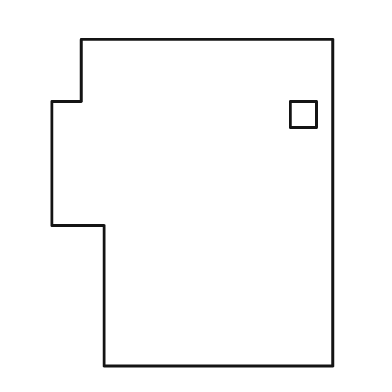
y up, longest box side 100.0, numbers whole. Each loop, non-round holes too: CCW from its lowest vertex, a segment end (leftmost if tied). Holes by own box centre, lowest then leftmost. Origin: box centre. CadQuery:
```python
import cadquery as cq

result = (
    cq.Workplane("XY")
    .moveTo(-27.0, -50.0)
    .lineTo(43.0, -50.0)
    .lineTo(43.0, 50.0)
    .lineTo(-34.0, 50.0)
    .lineTo(-34.0, 31.0)
    .lineTo(-43.0, 31.0)
    .lineTo(-43.0, -7.0)
    .lineTo(-27.0, -7.0)
    .close()
    .moveTo(30.0, 23.0)
    .lineTo(38.0, 23.0)
    .lineTo(38.0, 31.0)
    .lineTo(30.0, 31.0)
    .close()
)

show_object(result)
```